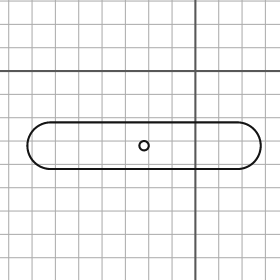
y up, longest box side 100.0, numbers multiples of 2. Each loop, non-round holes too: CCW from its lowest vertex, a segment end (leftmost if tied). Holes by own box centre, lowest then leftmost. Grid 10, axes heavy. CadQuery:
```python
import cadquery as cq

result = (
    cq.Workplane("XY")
    .moveTo(-62.0, -42.0)
    .lineTo(18.0, -42.0)
    .threePointArc((28.0, -32.0), (18.0, -22.0))
    .lineTo(-62.0, -22.0)
    .threePointArc((-72.0, -32.0), (-62.0, -42.0))
    .close()
    .moveTo(-22.0, -32.0)
    .circle(2.0)
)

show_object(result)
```